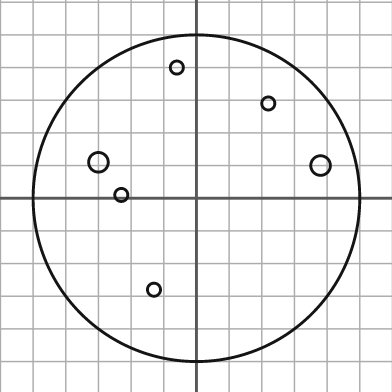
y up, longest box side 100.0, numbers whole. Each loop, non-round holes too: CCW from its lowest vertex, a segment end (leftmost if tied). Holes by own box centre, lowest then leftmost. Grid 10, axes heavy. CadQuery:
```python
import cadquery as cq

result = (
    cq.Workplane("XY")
    .moveTo(0.0, 0.0)
    .circle(50.0)
    .moveTo(-13.0, -28.0)
    .circle(2.0)
    .moveTo(-23.0, 1.0)
    .circle(2.0)
    .moveTo(38.0, 10.0)
    .circle(3.0)
    .moveTo(-30.0, 11.0)
    .circle(3.0)
    .moveTo(22.0, 29.0)
    .circle(2.0)
    .moveTo(-6.0, 40.0)
    .circle(2.0)
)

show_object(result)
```